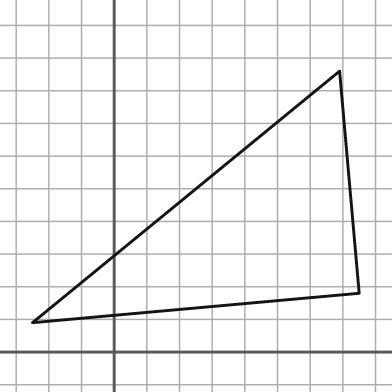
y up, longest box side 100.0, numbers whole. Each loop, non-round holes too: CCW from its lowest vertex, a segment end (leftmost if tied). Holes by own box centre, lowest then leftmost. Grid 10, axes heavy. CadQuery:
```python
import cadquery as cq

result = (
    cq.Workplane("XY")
    .moveTo(-25.0, 9.0)
    .lineTo(75.0, 18.0)
    .lineTo(69.0, 86.0)
    .close()
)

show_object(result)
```